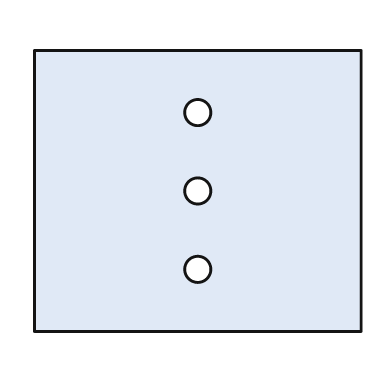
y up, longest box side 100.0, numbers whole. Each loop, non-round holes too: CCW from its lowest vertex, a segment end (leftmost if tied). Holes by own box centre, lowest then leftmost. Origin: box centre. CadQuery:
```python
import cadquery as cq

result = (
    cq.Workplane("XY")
    .moveTo(-50.0, -43.0)
    .lineTo(50.0, -43.0)
    .lineTo(50.0, 43.0)
    .lineTo(-50.0, 43.0)
    .close()
    .moveTo(0.0, -24.0)
    .circle(4.0)
    .moveTo(0.0, 0.0)
    .circle(4.0)
    .moveTo(0.0, 24.0)
    .circle(4.0)
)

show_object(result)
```